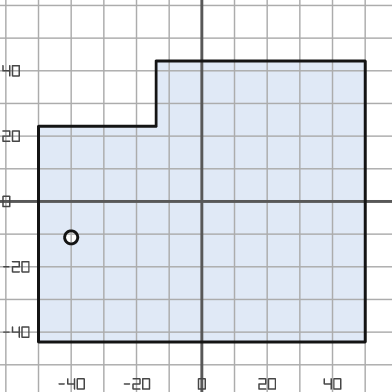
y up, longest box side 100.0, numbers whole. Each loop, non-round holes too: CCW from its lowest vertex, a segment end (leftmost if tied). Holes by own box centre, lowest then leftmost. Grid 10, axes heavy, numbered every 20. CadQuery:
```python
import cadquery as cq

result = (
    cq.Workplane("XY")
    .moveTo(-50.0, -43.0)
    .lineTo(50.0, -43.0)
    .lineTo(50.0, 43.0)
    .lineTo(-14.0, 43.0)
    .lineTo(-14.0, 23.0)
    .lineTo(-50.0, 23.0)
    .close()
    .moveTo(-40.0, -11.0)
    .circle(2.0)
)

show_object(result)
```